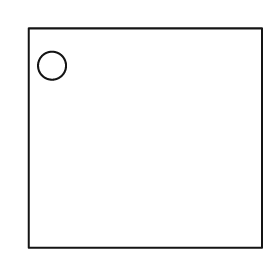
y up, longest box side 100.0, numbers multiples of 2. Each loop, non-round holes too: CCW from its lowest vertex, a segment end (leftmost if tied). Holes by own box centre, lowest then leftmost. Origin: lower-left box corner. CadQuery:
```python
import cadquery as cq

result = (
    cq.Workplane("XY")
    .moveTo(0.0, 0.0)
    .lineTo(100.0, 0.0)
    .lineTo(100.0, 94.0)
    .lineTo(0.0, 94.0)
    .close()
    .moveTo(10.0, 78.0)
    .circle(6.0)
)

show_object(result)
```